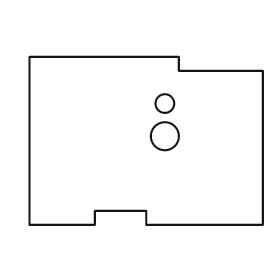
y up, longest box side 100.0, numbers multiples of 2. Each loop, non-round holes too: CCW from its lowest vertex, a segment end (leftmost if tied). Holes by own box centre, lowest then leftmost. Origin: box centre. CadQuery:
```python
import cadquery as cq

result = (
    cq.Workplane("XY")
    .moveTo(-50.0, -36.0)
    .lineTo(-22.0, -36.0)
    .lineTo(-22.0, -30.0)
    .lineTo(0.0, -30.0)
    .lineTo(0.0, -36.0)
    .lineTo(50.0, -36.0)
    .lineTo(50.0, 30.0)
    .lineTo(14.0, 30.0)
    .lineTo(14.0, 36.0)
    .lineTo(-50.0, 36.0)
    .close()
    .moveTo(8.0, 2.0)
    .circle(6.0)
    .moveTo(8.0, 16.0)
    .circle(4.0)
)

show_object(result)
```